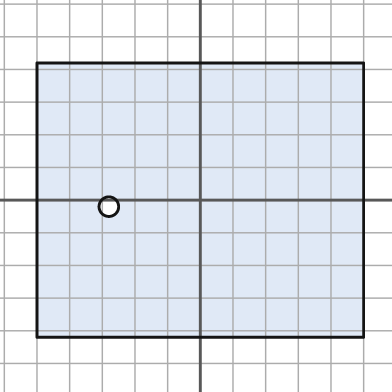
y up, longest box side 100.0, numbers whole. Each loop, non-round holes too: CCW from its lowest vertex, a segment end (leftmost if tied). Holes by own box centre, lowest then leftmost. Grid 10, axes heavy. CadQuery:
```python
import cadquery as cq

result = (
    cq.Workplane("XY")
    .moveTo(-50.0, -42.0)
    .lineTo(50.0, -42.0)
    .lineTo(50.0, 42.0)
    .lineTo(-50.0, 42.0)
    .close()
    .moveTo(-28.0, -2.0)
    .circle(3.0)
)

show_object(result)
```